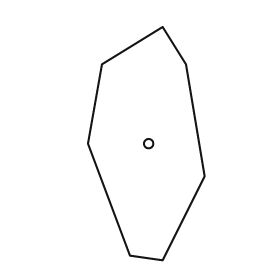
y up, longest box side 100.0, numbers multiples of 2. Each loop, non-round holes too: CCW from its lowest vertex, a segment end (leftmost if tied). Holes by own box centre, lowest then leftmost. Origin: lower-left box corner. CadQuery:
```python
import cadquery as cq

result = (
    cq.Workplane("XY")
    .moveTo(32.0, 0.0)
    .lineTo(50.0, 36.0)
    .lineTo(42.0, 84.0)
    .lineTo(32.0, 100.0)
    .lineTo(6.0, 84.0)
    .lineTo(0.0, 50.0)
    .lineTo(18.0, 2.0)
    .close()
    .moveTo(26.0, 50.0)
    .circle(2.0)
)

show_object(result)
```